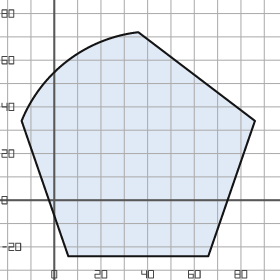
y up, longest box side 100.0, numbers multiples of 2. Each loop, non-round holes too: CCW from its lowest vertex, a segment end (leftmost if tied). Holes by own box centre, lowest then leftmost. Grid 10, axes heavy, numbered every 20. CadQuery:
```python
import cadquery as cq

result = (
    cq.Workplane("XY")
    .moveTo(6.0, -24.0)
    .lineTo(66.0, -24.0)
    .lineTo(86.0, 34.0)
    .lineTo(36.0, 72.0)
    .threePointArc((6.0, 60.0), (-14.0, 34.0))
    .close()
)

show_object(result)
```